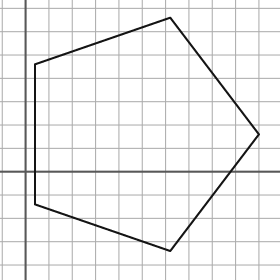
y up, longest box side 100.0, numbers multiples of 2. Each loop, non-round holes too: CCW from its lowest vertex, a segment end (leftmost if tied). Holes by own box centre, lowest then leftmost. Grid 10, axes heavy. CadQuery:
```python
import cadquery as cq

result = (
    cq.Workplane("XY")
    .moveTo(62.0, -34.0)
    .lineTo(100.0, 16.0)
    .lineTo(62.0, 66.0)
    .lineTo(4.0, 46.0)
    .lineTo(4.0, -14.0)
    .close()
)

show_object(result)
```